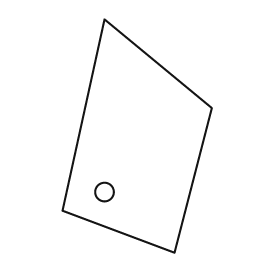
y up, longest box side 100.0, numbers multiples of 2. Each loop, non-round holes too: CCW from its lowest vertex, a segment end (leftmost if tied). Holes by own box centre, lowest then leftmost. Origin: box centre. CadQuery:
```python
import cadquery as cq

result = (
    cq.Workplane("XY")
    .moveTo(16.0, -50.0)
    .lineTo(32.0, 12.0)
    .lineTo(-14.0, 50.0)
    .lineTo(-32.0, -32.0)
    .close()
    .moveTo(-14.0, -24.0)
    .circle(4.0)
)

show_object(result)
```